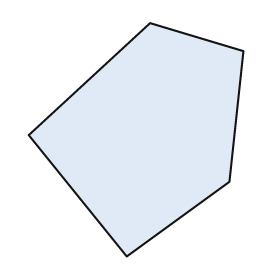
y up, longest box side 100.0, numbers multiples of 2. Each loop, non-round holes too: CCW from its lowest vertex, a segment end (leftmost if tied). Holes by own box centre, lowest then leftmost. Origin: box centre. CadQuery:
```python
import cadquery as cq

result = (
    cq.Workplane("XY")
    .moveTo(-4.0, -50.0)
    .lineTo(40.0, -18.0)
    .lineTo(46.0, 38.0)
    .lineTo(6.0, 50.0)
    .lineTo(-46.0, 2.0)
    .close()
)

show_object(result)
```